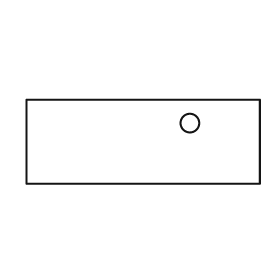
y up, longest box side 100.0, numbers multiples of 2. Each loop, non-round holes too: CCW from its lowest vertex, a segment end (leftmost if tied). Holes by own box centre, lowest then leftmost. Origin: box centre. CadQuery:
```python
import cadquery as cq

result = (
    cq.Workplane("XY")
    .moveTo(-50.0, -18.0)
    .lineTo(50.0, -18.0)
    .lineTo(50.0, 18.0)
    .lineTo(-50.0, 18.0)
    .close()
    .moveTo(20.0, 8.0)
    .circle(4.0)
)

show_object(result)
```